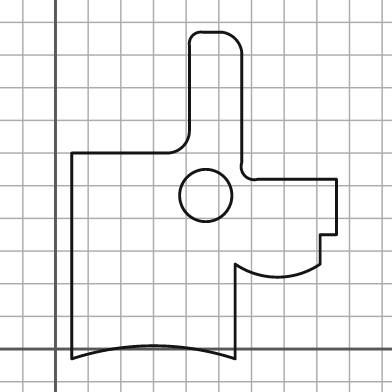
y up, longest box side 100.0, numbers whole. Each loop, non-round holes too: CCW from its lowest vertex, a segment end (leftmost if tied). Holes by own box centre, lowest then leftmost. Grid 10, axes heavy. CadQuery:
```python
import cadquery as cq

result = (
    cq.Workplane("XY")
    .moveTo(5.0, -3.0)
    .threePointArc((30.0, 1.0), (55.0, -3.0))
    .lineTo(55.0, 26.0)
    .threePointArc((68.0, 22.0), (81.0, 26.0))
    .lineTo(81.0, 35.0)
    .lineTo(86.0, 35.0)
    .lineTo(86.0, 52.0)
    .lineTo(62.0, 52.0)
    .threePointArc((58.0, 53.0), (57.0, 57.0))
    .lineTo(57.0, 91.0)
    .threePointArc((55.0, 95.0), (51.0, 97.0))
    .lineTo(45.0, 97.0)
    .threePointArc((42.0, 96.0), (41.0, 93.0))
    .lineTo(41.0, 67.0)
    .threePointArc((39.0, 62.0), (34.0, 60.0))
    .lineTo(5.0, 60.0)
    .close()
    .moveTo(46.0, 47.0)
    .circle(8.0)
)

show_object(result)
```